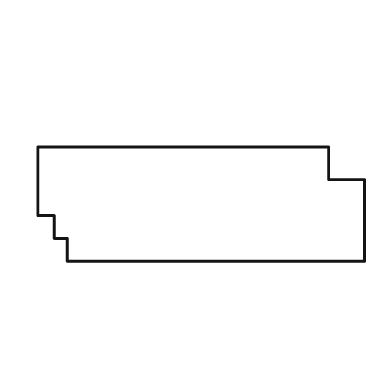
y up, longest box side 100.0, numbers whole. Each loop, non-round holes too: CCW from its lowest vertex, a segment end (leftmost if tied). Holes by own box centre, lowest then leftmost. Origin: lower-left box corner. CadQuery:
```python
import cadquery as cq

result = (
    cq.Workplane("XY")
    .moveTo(9.0, 0.0)
    .lineTo(100.0, 0.0)
    .lineTo(100.0, 25.0)
    .lineTo(89.0, 25.0)
    .lineTo(89.0, 35.0)
    .lineTo(0.0, 35.0)
    .lineTo(0.0, 14.0)
    .lineTo(5.0, 14.0)
    .lineTo(5.0, 7.0)
    .lineTo(9.0, 7.0)
    .close()
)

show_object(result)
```